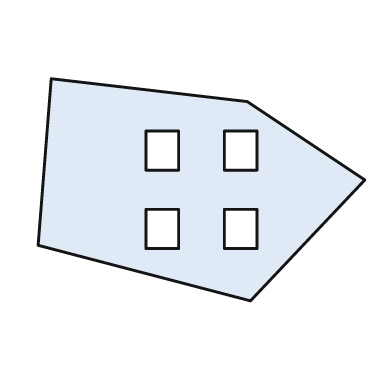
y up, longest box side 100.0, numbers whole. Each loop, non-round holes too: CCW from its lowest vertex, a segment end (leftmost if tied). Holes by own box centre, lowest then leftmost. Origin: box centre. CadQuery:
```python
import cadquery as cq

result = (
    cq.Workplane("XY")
    .moveTo(15.0, -34.0)
    .lineTo(50.0, 3.0)
    .lineTo(14.0, 27.0)
    .lineTo(-46.0, 34.0)
    .lineTo(-50.0, -17.0)
    .close()
    .moveTo(-17.0, -18.0)
    .lineTo(-7.0, -18.0)
    .lineTo(-7.0, -6.0)
    .lineTo(-17.0, -6.0)
    .close()
    .moveTo(7.0, -18.0)
    .lineTo(17.0, -18.0)
    .lineTo(17.0, -6.0)
    .lineTo(7.0, -6.0)
    .close()
    .moveTo(-17.0, 6.0)
    .lineTo(-7.0, 6.0)
    .lineTo(-7.0, 18.0)
    .lineTo(-17.0, 18.0)
    .close()
    .moveTo(7.0, 6.0)
    .lineTo(17.0, 6.0)
    .lineTo(17.0, 18.0)
    .lineTo(7.0, 18.0)
    .close()
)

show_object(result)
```